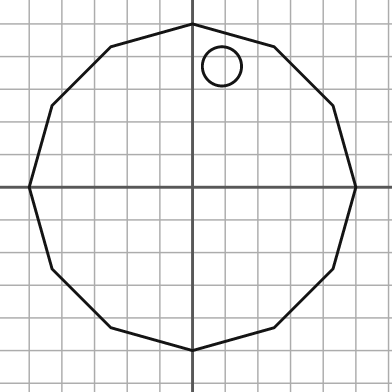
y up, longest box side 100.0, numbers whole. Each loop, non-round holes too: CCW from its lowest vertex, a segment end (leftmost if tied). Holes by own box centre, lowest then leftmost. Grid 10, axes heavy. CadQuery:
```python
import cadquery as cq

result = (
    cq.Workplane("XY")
    .moveTo(0.0, -50.0)
    .lineTo(25.0, -43.0)
    .lineTo(43.0, -25.0)
    .lineTo(50.0, 0.0)
    .lineTo(43.0, 25.0)
    .lineTo(25.0, 43.0)
    .lineTo(0.0, 50.0)
    .lineTo(-25.0, 43.0)
    .lineTo(-43.0, 25.0)
    .lineTo(-50.0, 0.0)
    .lineTo(-43.0, -25.0)
    .lineTo(-25.0, -43.0)
    .close()
    .moveTo(9.0, 37.0)
    .circle(6.0)
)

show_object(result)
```